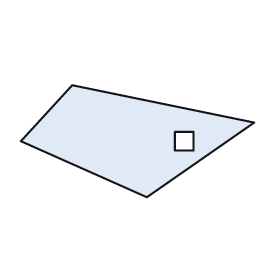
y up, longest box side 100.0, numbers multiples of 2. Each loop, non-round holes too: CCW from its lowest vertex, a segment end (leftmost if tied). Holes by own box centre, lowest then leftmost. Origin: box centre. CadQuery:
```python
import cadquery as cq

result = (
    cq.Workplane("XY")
    .moveTo(4.0, -24.0)
    .lineTo(50.0, 8.0)
    .lineTo(-28.0, 24.0)
    .lineTo(-50.0, 0.0)
    .close()
    .moveTo(16.0, -4.0)
    .lineTo(24.0, -4.0)
    .lineTo(24.0, 4.0)
    .lineTo(16.0, 4.0)
    .close()
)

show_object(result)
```